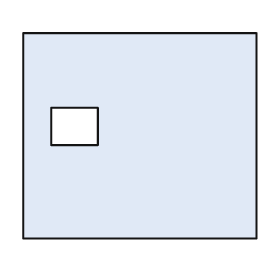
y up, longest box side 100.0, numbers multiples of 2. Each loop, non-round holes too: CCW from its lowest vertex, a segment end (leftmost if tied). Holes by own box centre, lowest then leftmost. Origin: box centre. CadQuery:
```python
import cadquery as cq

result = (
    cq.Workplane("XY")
    .moveTo(-50.0, -44.0)
    .lineTo(50.0, -44.0)
    .lineTo(50.0, 44.0)
    .lineTo(-50.0, 44.0)
    .close()
    .moveTo(-38.0, -4.0)
    .lineTo(-18.0, -4.0)
    .lineTo(-18.0, 12.0)
    .lineTo(-38.0, 12.0)
    .close()
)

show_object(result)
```